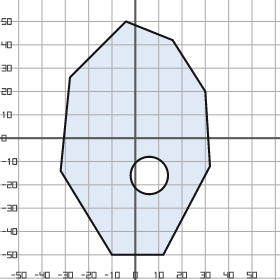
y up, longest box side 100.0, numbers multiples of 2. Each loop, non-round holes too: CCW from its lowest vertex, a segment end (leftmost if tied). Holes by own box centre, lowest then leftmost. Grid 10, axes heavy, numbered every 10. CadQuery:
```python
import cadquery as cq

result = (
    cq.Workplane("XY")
    .moveTo(-10.0, -50.0)
    .lineTo(12.0, -50.0)
    .lineTo(32.0, -12.0)
    .lineTo(30.0, 20.0)
    .lineTo(16.0, 42.0)
    .lineTo(-4.0, 50.0)
    .lineTo(-28.0, 26.0)
    .lineTo(-32.0, -14.0)
    .close()
    .moveTo(6.0, -16.0)
    .circle(8.0)
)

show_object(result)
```